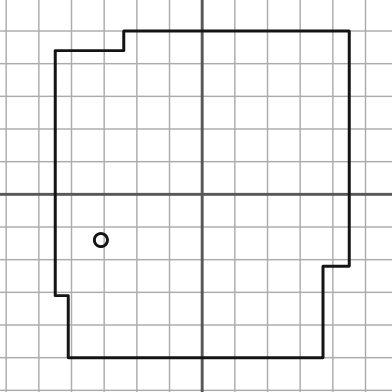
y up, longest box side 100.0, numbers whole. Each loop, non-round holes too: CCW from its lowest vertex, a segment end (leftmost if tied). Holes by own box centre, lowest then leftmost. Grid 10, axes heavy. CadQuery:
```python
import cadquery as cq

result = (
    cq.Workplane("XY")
    .moveTo(-41.0, -50.0)
    .lineTo(37.0, -50.0)
    .lineTo(37.0, -22.0)
    .lineTo(45.0, -22.0)
    .lineTo(45.0, 50.0)
    .lineTo(-24.0, 50.0)
    .lineTo(-24.0, 44.0)
    .lineTo(-45.0, 44.0)
    .lineTo(-45.0, -31.0)
    .lineTo(-41.0, -31.0)
    .close()
    .moveTo(-31.0, -14.0)
    .circle(2.0)
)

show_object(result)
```